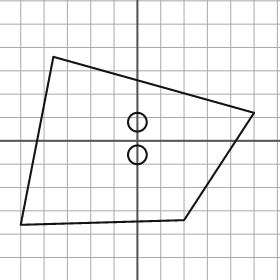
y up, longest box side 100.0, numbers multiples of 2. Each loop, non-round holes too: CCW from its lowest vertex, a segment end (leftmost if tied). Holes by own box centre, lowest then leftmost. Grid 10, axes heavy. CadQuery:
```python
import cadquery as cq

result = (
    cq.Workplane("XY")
    .moveTo(-50.0, -36.0)
    .lineTo(20.0, -34.0)
    .lineTo(50.0, 12.0)
    .lineTo(-36.0, 36.0)
    .close()
    .moveTo(0.0, -6.0)
    .circle(4.0)
    .moveTo(0.0, 8.0)
    .circle(4.0)
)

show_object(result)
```